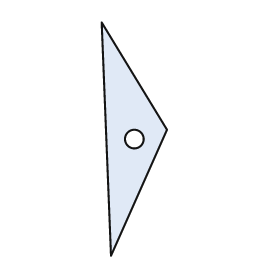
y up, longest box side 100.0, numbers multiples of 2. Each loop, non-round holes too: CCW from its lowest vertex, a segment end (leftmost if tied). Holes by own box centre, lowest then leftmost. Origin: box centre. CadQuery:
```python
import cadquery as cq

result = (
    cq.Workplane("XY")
    .moveTo(-10.0, -50.0)
    .lineTo(14.0, 4.0)
    .lineTo(-14.0, 50.0)
    .close()
    .moveTo(0.0, 0.0)
    .circle(4.0)
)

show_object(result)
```